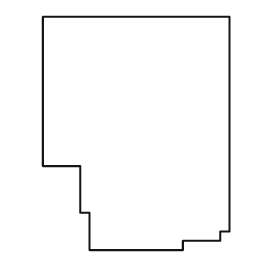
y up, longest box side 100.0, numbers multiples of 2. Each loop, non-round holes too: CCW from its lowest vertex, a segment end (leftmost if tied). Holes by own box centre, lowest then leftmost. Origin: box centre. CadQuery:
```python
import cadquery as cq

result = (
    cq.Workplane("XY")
    .moveTo(-20.0, -50.0)
    .lineTo(20.0, -50.0)
    .lineTo(20.0, -46.0)
    .lineTo(36.0, -46.0)
    .lineTo(36.0, -42.0)
    .lineTo(40.0, -42.0)
    .lineTo(40.0, 50.0)
    .lineTo(-40.0, 50.0)
    .lineTo(-40.0, -14.0)
    .lineTo(-24.0, -14.0)
    .lineTo(-24.0, -34.0)
    .lineTo(-20.0, -34.0)
    .close()
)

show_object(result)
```